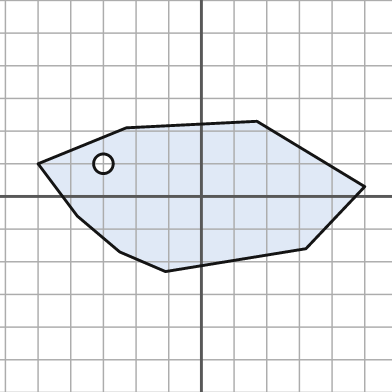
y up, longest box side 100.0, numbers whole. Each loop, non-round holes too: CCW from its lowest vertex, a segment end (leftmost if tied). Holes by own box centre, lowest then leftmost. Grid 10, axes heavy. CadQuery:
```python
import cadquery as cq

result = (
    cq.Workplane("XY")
    .moveTo(-11.0, -23.0)
    .lineTo(32.0, -16.0)
    .lineTo(50.0, 3.0)
    .lineTo(17.0, 23.0)
    .lineTo(-23.0, 21.0)
    .lineTo(-50.0, 10.0)
    .lineTo(-38.0, -6.0)
    .lineTo(-25.0, -17.0)
    .close()
    .moveTo(-30.0, 10.0)
    .circle(3.0)
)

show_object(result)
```